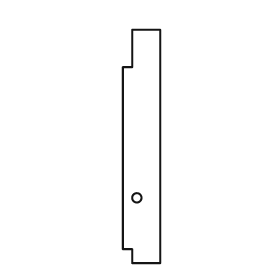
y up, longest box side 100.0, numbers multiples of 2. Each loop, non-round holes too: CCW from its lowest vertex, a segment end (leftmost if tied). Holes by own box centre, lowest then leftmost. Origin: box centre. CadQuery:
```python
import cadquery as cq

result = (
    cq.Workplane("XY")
    .moveTo(-4.0, -50.0)
    .lineTo(8.0, -50.0)
    .lineTo(8.0, 50.0)
    .lineTo(-4.0, 50.0)
    .lineTo(-4.0, 34.0)
    .lineTo(-8.0, 34.0)
    .lineTo(-8.0, -44.0)
    .lineTo(-4.0, -44.0)
    .close()
    .moveTo(-2.0, -22.0)
    .circle(2.0)
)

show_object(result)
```